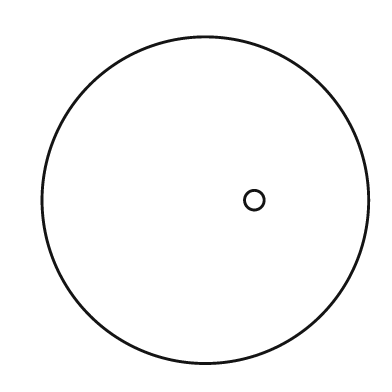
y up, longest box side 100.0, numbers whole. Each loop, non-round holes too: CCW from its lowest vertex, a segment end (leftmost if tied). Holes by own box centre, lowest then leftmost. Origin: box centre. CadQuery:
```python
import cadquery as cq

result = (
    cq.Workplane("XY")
    .moveTo(0.0, 0.0)
    .circle(50.0)
    .moveTo(15.0, 0.0)
    .circle(3.0)
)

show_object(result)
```